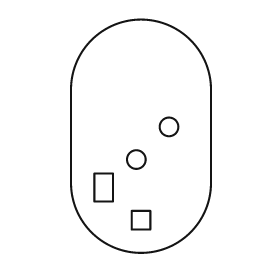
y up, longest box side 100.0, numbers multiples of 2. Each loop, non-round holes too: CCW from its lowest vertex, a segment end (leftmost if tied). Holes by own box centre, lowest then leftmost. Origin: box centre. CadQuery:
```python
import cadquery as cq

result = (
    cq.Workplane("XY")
    .moveTo(-30.0, -20.0)
    .threePointArc((0.0, -50.0), (30.0, -20.0))
    .lineTo(30.0, 20.0)
    .threePointArc((0.0, 50.0), (-30.0, 20.0))
    .close()
    .moveTo(-4.0, -40.0)
    .lineTo(4.0, -40.0)
    .lineTo(4.0, -32.0)
    .lineTo(-4.0, -32.0)
    .close()
    .moveTo(-20.0, -28.0)
    .lineTo(-12.0, -28.0)
    .lineTo(-12.0, -16.0)
    .lineTo(-20.0, -16.0)
    .close()
    .moveTo(-2.0, -10.0)
    .circle(4.0)
    .moveTo(12.0, 4.0)
    .circle(4.0)
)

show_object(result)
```